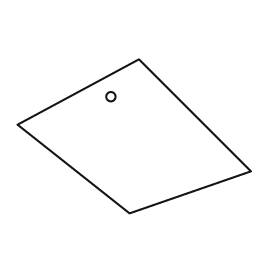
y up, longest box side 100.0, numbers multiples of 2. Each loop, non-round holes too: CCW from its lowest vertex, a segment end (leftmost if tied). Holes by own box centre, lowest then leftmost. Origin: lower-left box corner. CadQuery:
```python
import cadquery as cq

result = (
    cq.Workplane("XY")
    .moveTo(48.0, 0.0)
    .lineTo(100.0, 18.0)
    .lineTo(52.0, 66.0)
    .lineTo(0.0, 38.0)
    .close()
    .moveTo(40.0, 50.0)
    .circle(2.0)
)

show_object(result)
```